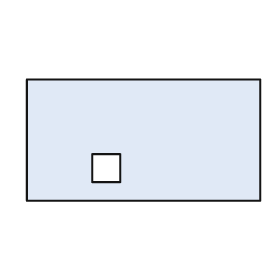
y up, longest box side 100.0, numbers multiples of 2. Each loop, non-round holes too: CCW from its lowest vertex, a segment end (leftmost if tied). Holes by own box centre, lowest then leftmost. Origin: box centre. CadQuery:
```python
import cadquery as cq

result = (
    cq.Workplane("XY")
    .moveTo(-50.0, -26.0)
    .lineTo(50.0, -26.0)
    .lineTo(50.0, 26.0)
    .lineTo(-50.0, 26.0)
    .close()
    .moveTo(-22.0, -18.0)
    .lineTo(-10.0, -18.0)
    .lineTo(-10.0, -6.0)
    .lineTo(-22.0, -6.0)
    .close()
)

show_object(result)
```